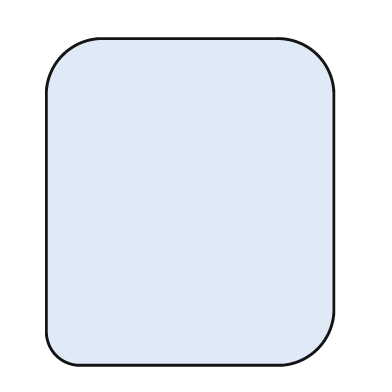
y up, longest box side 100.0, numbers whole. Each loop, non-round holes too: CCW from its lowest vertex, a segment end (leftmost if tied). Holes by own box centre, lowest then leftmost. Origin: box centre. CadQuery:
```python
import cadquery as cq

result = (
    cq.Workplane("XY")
    .moveTo(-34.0, -50.0)
    .lineTo(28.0, -50.0)
    .threePointArc((39.0, -45.0), (44.0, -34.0))
    .lineTo(44.0, 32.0)
    .threePointArc((39.0, 45.0), (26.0, 50.0))
    .lineTo(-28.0, 50.0)
    .threePointArc((-39.0, 45.0), (-44.0, 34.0))
    .lineTo(-44.0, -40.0)
    .threePointArc((-41.0, -47.0), (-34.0, -50.0))
    .close()
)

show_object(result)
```